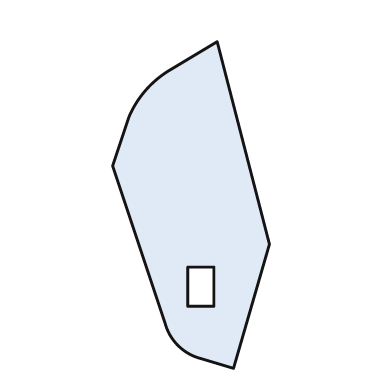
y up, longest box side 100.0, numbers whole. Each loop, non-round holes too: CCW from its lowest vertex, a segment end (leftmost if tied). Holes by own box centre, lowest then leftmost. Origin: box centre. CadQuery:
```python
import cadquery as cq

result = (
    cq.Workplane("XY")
    .moveTo(13.0, -50.0)
    .lineTo(24.0, -12.0)
    .lineTo(8.0, 50.0)
    .lineTo(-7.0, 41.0)
    .threePointArc((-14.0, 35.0), (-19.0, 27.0))
    .lineTo(-24.0, 12.0)
    .lineTo(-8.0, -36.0)
    .threePointArc((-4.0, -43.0), (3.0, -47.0))
    .close()
    .moveTo(-1.0, -31.0)
    .lineTo(7.0, -31.0)
    .lineTo(7.0, -19.0)
    .lineTo(-1.0, -19.0)
    .close()
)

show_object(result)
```